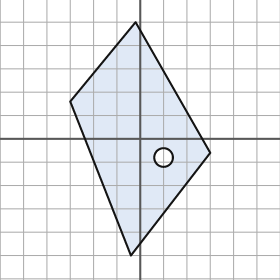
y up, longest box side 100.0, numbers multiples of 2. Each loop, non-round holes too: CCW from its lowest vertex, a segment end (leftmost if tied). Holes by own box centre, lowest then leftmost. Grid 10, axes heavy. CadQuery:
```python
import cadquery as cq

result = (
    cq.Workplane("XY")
    .moveTo(-4.0, -50.0)
    .lineTo(30.0, -6.0)
    .lineTo(-2.0, 50.0)
    .lineTo(-30.0, 16.0)
    .close()
    .moveTo(10.0, -8.0)
    .circle(4.0)
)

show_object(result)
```